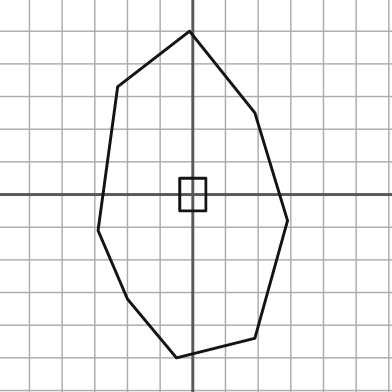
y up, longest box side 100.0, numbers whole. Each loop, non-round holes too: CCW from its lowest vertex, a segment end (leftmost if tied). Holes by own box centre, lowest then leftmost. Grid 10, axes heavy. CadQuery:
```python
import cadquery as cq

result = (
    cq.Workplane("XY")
    .moveTo(-5.0, -50.0)
    .lineTo(19.0, -44.0)
    .lineTo(29.0, -8.0)
    .lineTo(19.0, 25.0)
    .lineTo(-1.0, 50.0)
    .lineTo(-23.0, 33.0)
    .lineTo(-29.0, -11.0)
    .lineTo(-20.0, -32.0)
    .close()
    .moveTo(-4.0, -5.0)
    .lineTo(4.0, -5.0)
    .lineTo(4.0, 5.0)
    .lineTo(-4.0, 5.0)
    .close()
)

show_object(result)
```